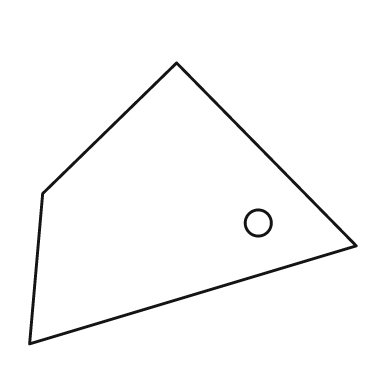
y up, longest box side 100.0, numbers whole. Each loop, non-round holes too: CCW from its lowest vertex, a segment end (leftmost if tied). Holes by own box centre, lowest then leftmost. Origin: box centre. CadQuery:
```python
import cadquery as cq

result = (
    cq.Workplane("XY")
    .moveTo(-50.0, -43.0)
    .lineTo(50.0, -13.0)
    .lineTo(-5.0, 43.0)
    .lineTo(-46.0, 3.0)
    .close()
    .moveTo(20.0, -6.0)
    .circle(4.0)
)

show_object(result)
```